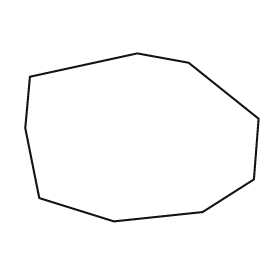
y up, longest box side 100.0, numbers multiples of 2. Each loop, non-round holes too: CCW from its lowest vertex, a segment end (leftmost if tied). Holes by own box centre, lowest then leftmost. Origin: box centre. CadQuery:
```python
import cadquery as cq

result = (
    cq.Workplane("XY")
    .moveTo(-12.0, -36.0)
    .lineTo(26.0, -32.0)
    .lineTo(48.0, -18.0)
    .lineTo(50.0, 8.0)
    .lineTo(20.0, 32.0)
    .lineTo(-2.0, 36.0)
    .lineTo(-48.0, 26.0)
    .lineTo(-50.0, 4.0)
    .lineTo(-44.0, -26.0)
    .close()
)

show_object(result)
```